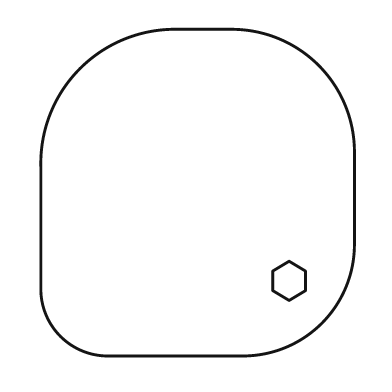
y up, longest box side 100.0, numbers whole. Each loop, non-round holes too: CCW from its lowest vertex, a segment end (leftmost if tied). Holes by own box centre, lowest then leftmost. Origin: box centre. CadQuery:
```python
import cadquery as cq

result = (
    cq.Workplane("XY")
    .moveTo(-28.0, -50.0)
    .lineTo(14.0, -50.0)
    .threePointArc((38.0, -40.0), (48.0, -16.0))
    .lineTo(48.0, 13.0)
    .threePointArc((37.0, 39.0), (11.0, 50.0))
    .lineTo(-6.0, 50.0)
    .threePointArc((-36.0, 38.0), (-48.0, 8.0))
    .lineTo(-48.0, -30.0)
    .threePointArc((-42.0, -44.0), (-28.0, -50.0))
    .close()
    .moveTo(28.0, -33.0)
    .lineTo(33.0, -30.0)
    .lineTo(33.0, -24.0)
    .lineTo(28.0, -21.0)
    .lineTo(23.0, -24.0)
    .lineTo(23.0, -30.0)
    .close()
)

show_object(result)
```